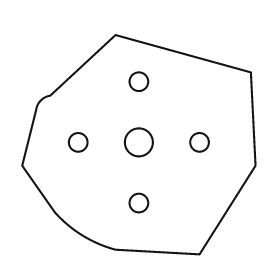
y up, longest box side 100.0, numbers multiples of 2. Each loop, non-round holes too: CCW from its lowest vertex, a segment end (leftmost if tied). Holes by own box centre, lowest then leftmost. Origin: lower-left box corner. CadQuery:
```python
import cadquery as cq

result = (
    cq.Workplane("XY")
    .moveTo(76.0, 0.0)
    .lineTo(100.0, 38.0)
    .lineTo(98.0, 78.0)
    .lineTo(40.0, 94.0)
    .lineTo(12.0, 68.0)
    .threePointArc((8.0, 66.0), (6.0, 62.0))
    .lineTo(0.0, 38.0)
    .lineTo(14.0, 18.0)
    .threePointArc((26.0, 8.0), (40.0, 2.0))
    .close()
    .moveTo(50.0, 22.0)
    .circle(4.0)
    .moveTo(24.0, 48.0)
    .circle(4.0)
    .moveTo(50.0, 48.0)
    .circle(6.0)
    .moveTo(76.0, 48.0)
    .circle(4.0)
    .moveTo(50.0, 74.0)
    .circle(4.0)
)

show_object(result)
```